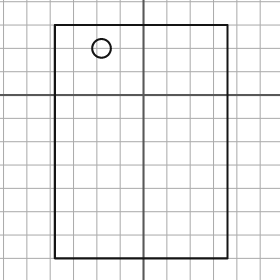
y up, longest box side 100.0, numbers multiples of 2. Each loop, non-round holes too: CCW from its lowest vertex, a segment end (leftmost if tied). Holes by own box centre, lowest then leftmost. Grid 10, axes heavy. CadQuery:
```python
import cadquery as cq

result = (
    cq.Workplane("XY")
    .moveTo(-38.0, -70.0)
    .lineTo(36.0, -70.0)
    .lineTo(36.0, 30.0)
    .lineTo(-38.0, 30.0)
    .close()
    .moveTo(-18.0, 20.0)
    .circle(4.0)
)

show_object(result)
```